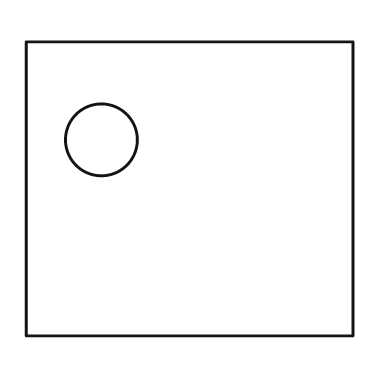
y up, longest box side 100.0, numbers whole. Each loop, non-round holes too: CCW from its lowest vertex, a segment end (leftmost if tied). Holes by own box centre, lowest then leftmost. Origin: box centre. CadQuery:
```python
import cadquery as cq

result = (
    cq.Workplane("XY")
    .moveTo(-50.0, -45.0)
    .lineTo(50.0, -45.0)
    .lineTo(50.0, 45.0)
    .lineTo(-50.0, 45.0)
    .close()
    .moveTo(-27.0, 15.0)
    .circle(11.0)
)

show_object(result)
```